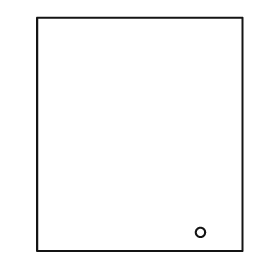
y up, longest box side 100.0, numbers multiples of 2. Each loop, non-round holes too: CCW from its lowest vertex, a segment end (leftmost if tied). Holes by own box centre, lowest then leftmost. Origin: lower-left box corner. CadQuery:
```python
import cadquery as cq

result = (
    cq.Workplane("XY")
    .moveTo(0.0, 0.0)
    .lineTo(88.0, 0.0)
    .lineTo(88.0, 100.0)
    .lineTo(0.0, 100.0)
    .close()
    .moveTo(70.0, 8.0)
    .circle(2.0)
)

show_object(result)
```